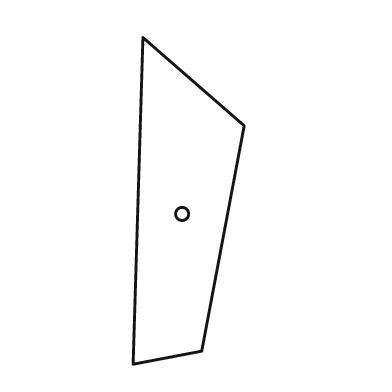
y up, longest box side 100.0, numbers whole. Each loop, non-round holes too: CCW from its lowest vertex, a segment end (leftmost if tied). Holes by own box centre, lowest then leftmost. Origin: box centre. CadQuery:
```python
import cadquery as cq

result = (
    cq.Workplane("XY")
    .moveTo(-17.0, -50.0)
    .lineTo(4.0, -46.0)
    .lineTo(17.0, 23.0)
    .lineTo(-14.0, 50.0)
    .close()
    .moveTo(-2.0, -4.0)
    .circle(2.0)
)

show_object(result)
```